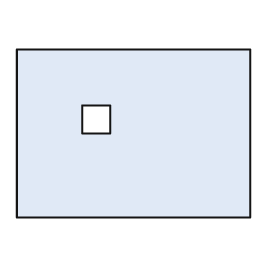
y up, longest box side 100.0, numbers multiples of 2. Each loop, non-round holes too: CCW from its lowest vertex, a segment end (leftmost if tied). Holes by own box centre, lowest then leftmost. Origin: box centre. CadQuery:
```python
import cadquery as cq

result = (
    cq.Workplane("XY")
    .moveTo(-50.0, -36.0)
    .lineTo(50.0, -36.0)
    .lineTo(50.0, 36.0)
    .lineTo(-50.0, 36.0)
    .close()
    .moveTo(-22.0, 0.0)
    .lineTo(-10.0, 0.0)
    .lineTo(-10.0, 12.0)
    .lineTo(-22.0, 12.0)
    .close()
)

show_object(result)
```